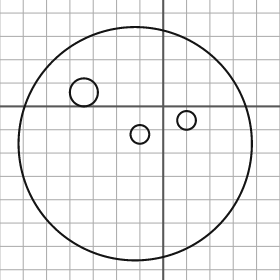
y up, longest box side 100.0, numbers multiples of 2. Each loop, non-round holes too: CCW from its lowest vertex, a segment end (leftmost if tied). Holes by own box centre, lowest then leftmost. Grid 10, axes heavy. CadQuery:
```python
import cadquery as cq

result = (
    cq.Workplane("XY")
    .moveTo(-12.0, -16.0)
    .circle(50.0)
    .moveTo(-10.0, -12.0)
    .circle(4.0)
    .moveTo(10.0, -6.0)
    .circle(4.0)
    .moveTo(-34.0, 6.0)
    .circle(6.0)
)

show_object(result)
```